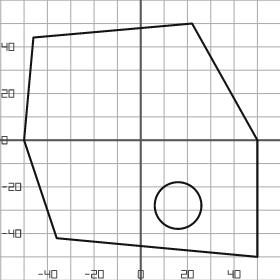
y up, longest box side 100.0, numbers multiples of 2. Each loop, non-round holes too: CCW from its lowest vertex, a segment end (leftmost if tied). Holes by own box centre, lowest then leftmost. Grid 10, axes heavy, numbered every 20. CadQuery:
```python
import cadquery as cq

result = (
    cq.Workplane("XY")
    .moveTo(50.0, -50.0)
    .lineTo(50.0, 0.0)
    .lineTo(22.0, 50.0)
    .lineTo(-46.0, 44.0)
    .lineTo(-50.0, 0.0)
    .lineTo(-36.0, -42.0)
    .close()
    .moveTo(16.0, -28.0)
    .circle(10.0)
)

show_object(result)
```